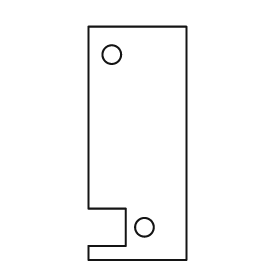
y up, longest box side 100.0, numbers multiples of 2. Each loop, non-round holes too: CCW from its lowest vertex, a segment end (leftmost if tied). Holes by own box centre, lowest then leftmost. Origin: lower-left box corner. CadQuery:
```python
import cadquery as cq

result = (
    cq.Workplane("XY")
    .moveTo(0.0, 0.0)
    .lineTo(42.0, 0.0)
    .lineTo(42.0, 100.0)
    .lineTo(0.0, 100.0)
    .lineTo(0.0, 22.0)
    .lineTo(16.0, 22.0)
    .lineTo(16.0, 6.0)
    .lineTo(0.0, 6.0)
    .close()
    .moveTo(24.0, 14.0)
    .circle(4.0)
    .moveTo(10.0, 88.0)
    .circle(4.0)
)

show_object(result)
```